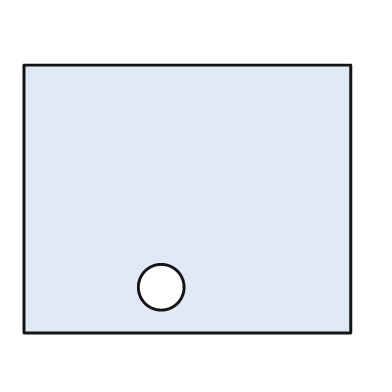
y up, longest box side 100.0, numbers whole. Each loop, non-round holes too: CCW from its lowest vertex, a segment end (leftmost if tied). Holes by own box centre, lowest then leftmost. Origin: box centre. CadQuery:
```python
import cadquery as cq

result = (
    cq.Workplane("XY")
    .moveTo(-50.0, -41.0)
    .lineTo(50.0, -41.0)
    .lineTo(50.0, 41.0)
    .lineTo(-50.0, 41.0)
    .close()
    .moveTo(-8.0, -27.0)
    .circle(7.0)
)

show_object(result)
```